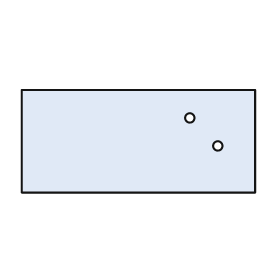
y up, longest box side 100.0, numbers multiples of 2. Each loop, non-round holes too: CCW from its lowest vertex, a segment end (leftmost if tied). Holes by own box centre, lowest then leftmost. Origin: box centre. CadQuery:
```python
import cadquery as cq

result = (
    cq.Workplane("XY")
    .moveTo(-50.0, -22.0)
    .lineTo(50.0, -22.0)
    .lineTo(50.0, 22.0)
    .lineTo(-50.0, 22.0)
    .close()
    .moveTo(34.0, -2.0)
    .circle(2.0)
    .moveTo(22.0, 10.0)
    .circle(2.0)
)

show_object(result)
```